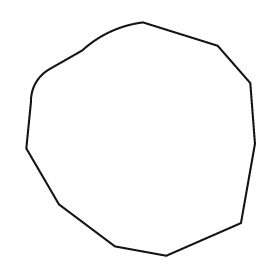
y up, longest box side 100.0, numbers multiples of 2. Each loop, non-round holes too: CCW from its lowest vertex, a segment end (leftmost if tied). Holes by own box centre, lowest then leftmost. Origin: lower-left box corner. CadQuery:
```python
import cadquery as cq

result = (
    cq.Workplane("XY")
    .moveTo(60.0, 0.0)
    .lineTo(92.0, 14.0)
    .lineTo(98.0, 48.0)
    .lineTo(96.0, 74.0)
    .lineTo(82.0, 90.0)
    .lineTo(50.0, 100.0)
    .threePointArc((36.0, 96.0), (24.0, 88.0))
    .lineTo(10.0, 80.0)
    .threePointArc((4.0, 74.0), (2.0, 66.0))
    .lineTo(0.0, 46.0)
    .lineTo(14.0, 22.0)
    .lineTo(38.0, 4.0)
    .close()
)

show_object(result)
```